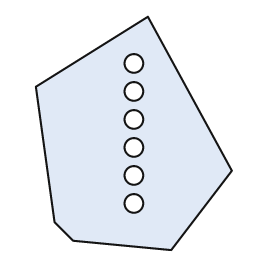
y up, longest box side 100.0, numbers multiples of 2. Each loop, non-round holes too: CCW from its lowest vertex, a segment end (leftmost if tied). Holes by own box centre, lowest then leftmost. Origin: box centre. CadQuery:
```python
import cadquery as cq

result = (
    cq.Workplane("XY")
    .moveTo(16.0, -50.0)
    .lineTo(42.0, -16.0)
    .lineTo(6.0, 50.0)
    .lineTo(-42.0, 20.0)
    .lineTo(-34.0, -38.0)
    .lineTo(-26.0, -46.0)
    .close()
    .moveTo(0.0, -30.0)
    .circle(4.0)
    .moveTo(0.0, -18.0)
    .circle(4.0)
    .moveTo(0.0, -6.0)
    .circle(4.0)
    .moveTo(0.0, 6.0)
    .circle(4.0)
    .moveTo(0.0, 18.0)
    .circle(4.0)
    .moveTo(0.0, 30.0)
    .circle(4.0)
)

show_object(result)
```